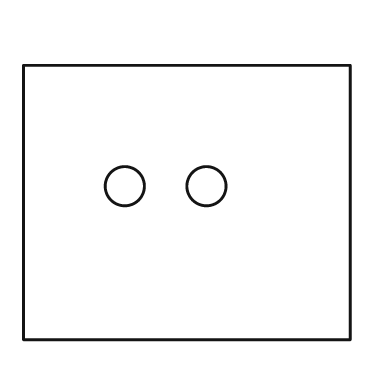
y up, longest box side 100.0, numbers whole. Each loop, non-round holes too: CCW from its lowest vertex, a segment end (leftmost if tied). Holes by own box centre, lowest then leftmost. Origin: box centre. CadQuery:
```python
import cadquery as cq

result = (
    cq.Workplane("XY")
    .moveTo(-50.0, -42.0)
    .lineTo(50.0, -42.0)
    .lineTo(50.0, 42.0)
    .lineTo(-50.0, 42.0)
    .close()
    .moveTo(-19.0, 5.0)
    .circle(6.0)
    .moveTo(6.0, 5.0)
    .circle(6.0)
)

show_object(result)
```